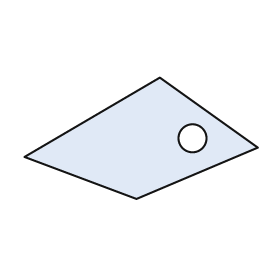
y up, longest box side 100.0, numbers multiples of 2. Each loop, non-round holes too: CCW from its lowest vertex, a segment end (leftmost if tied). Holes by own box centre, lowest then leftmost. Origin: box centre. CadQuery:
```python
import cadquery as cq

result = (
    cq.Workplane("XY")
    .moveTo(-2.0, -26.0)
    .lineTo(50.0, -4.0)
    .lineTo(8.0, 26.0)
    .lineTo(-50.0, -8.0)
    .close()
    .moveTo(22.0, 0.0)
    .circle(6.0)
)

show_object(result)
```